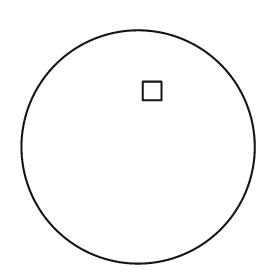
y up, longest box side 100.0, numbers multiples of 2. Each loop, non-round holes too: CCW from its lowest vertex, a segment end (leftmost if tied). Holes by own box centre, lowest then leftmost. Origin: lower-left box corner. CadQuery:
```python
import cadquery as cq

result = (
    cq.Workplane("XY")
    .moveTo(50.0, 50.0)
    .circle(50.0)
    .moveTo(52.0, 70.0)
    .lineTo(60.0, 70.0)
    .lineTo(60.0, 78.0)
    .lineTo(52.0, 78.0)
    .close()
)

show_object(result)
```